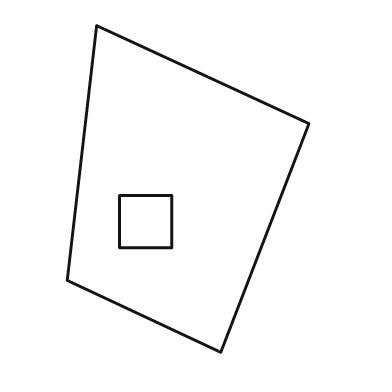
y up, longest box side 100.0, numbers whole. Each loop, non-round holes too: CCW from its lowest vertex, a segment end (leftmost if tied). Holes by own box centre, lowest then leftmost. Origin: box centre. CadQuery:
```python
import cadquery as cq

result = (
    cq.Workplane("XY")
    .moveTo(10.0, -50.0)
    .lineTo(37.0, 20.0)
    .lineTo(-28.0, 50.0)
    .lineTo(-37.0, -28.0)
    .close()
    .moveTo(-21.0, -18.0)
    .lineTo(-5.0, -18.0)
    .lineTo(-5.0, -2.0)
    .lineTo(-21.0, -2.0)
    .close()
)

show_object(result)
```